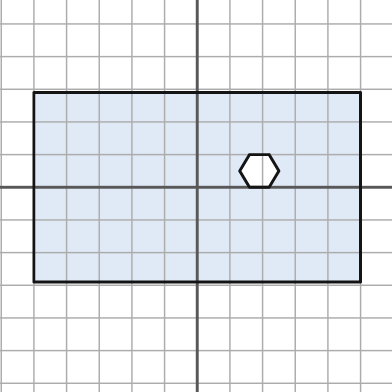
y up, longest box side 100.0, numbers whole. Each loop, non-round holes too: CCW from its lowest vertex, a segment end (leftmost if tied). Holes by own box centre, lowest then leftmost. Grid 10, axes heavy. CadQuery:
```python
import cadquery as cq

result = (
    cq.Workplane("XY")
    .moveTo(-50.0, -29.0)
    .lineTo(50.0, -29.0)
    .lineTo(50.0, 29.0)
    .lineTo(-50.0, 29.0)
    .close()
    .moveTo(16.0, 0.0)
    .lineTo(22.0, 0.0)
    .lineTo(25.0, 5.0)
    .lineTo(22.0, 10.0)
    .lineTo(16.0, 10.0)
    .lineTo(13.0, 5.0)
    .close()
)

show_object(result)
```